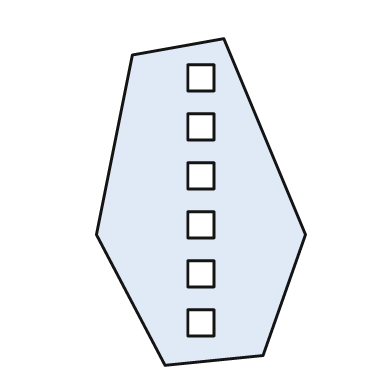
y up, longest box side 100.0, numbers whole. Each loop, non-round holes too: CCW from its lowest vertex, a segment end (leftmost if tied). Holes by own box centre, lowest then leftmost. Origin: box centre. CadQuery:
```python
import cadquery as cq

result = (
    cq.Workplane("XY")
    .moveTo(-11.0, -50.0)
    .lineTo(19.0, -47.0)
    .lineTo(32.0, -10.0)
    .lineTo(7.0, 50.0)
    .lineTo(-21.0, 45.0)
    .lineTo(-32.0, -10.0)
    .close()
    .moveTo(-4.0, -41.0)
    .lineTo(4.0, -41.0)
    .lineTo(4.0, -33.0)
    .lineTo(-4.0, -33.0)
    .close()
    .moveTo(-4.0, -26.0)
    .lineTo(4.0, -26.0)
    .lineTo(4.0, -18.0)
    .lineTo(-4.0, -18.0)
    .close()
    .moveTo(-4.0, -11.0)
    .lineTo(4.0, -11.0)
    .lineTo(4.0, -3.0)
    .lineTo(-4.0, -3.0)
    .close()
    .moveTo(-4.0, 4.0)
    .lineTo(4.0, 4.0)
    .lineTo(4.0, 12.0)
    .lineTo(-4.0, 12.0)
    .close()
    .moveTo(-4.0, 19.0)
    .lineTo(4.0, 19.0)
    .lineTo(4.0, 27.0)
    .lineTo(-4.0, 27.0)
    .close()
    .moveTo(-4.0, 34.0)
    .lineTo(4.0, 34.0)
    .lineTo(4.0, 42.0)
    .lineTo(-4.0, 42.0)
    .close()
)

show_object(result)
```